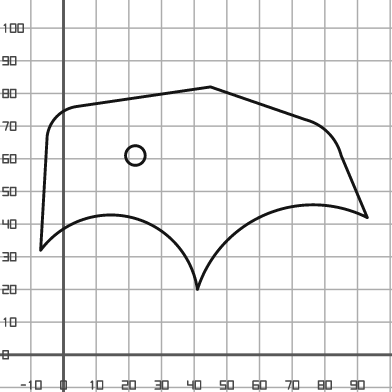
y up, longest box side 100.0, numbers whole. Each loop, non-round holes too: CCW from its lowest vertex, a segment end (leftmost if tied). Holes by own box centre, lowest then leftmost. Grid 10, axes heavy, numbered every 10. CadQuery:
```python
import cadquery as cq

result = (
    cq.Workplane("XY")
    .moveTo(41.0, 20.0)
    .threePointArc((62.0, 43.0), (93.0, 42.0))
    .lineTo(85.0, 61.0)
    .threePointArc((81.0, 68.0), (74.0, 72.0))
    .lineTo(45.0, 82.0)
    .lineTo(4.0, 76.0)
    .threePointArc((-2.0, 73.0), (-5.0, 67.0))
    .lineTo(-7.0, 32.0)
    .threePointArc((21.0, 42.0), (41.0, 20.0))
    .close()
    .moveTo(22.0, 61.0)
    .circle(3.0)
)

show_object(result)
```